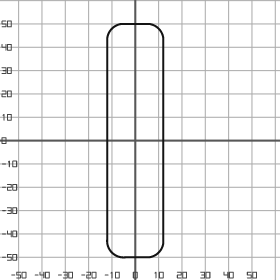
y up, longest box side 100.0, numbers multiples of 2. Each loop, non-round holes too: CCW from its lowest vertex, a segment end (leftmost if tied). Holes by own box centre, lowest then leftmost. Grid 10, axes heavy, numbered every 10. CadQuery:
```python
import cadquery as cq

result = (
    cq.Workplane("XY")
    .moveTo(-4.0, -50.0)
    .lineTo(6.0, -50.0)
    .threePointArc((10.0, -48.0), (12.0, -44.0))
    .lineTo(12.0, 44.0)
    .threePointArc((10.0, 48.0), (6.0, 50.0))
    .lineTo(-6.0, 50.0)
    .threePointArc((-10.0, 48.0), (-12.0, 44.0))
    .lineTo(-12.0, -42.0)
    .threePointArc((-10.0, -48.0), (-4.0, -50.0))
    .close()
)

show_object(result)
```